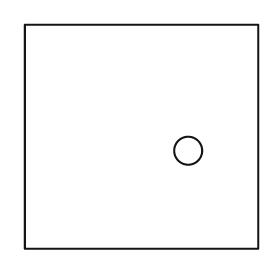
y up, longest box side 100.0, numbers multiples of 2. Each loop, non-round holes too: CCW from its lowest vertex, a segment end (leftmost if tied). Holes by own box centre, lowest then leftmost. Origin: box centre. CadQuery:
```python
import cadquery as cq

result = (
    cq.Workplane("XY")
    .moveTo(-50.0, -48.0)
    .lineTo(50.0, -48.0)
    .lineTo(50.0, 48.0)
    .lineTo(-50.0, 48.0)
    .close()
    .moveTo(20.0, -6.0)
    .circle(6.0)
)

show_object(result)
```